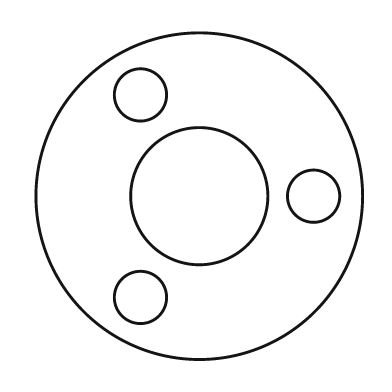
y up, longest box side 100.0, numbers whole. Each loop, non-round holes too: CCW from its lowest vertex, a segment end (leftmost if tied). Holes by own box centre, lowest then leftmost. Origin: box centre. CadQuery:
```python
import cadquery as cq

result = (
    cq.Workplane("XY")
    .moveTo(0.0, 0.0)
    .circle(50.0)
    .moveTo(-18.0, -31.0)
    .circle(8.0)
    .moveTo(0.0, 0.0)
    .circle(21.0)
    .moveTo(35.0, 0.0)
    .circle(8.0)
    .moveTo(-18.0, 31.0)
    .circle(8.0)
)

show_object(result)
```